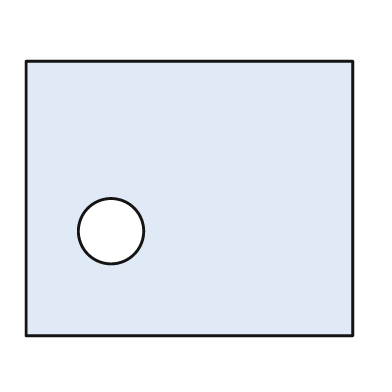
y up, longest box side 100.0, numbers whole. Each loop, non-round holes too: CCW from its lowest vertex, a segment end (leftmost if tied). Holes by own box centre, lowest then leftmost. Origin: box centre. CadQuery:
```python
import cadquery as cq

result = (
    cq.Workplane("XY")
    .moveTo(-50.0, -42.0)
    .lineTo(50.0, -42.0)
    .lineTo(50.0, 42.0)
    .lineTo(-50.0, 42.0)
    .close()
    .moveTo(-24.0, -10.0)
    .circle(10.0)
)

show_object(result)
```